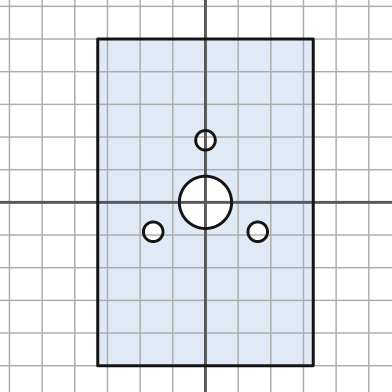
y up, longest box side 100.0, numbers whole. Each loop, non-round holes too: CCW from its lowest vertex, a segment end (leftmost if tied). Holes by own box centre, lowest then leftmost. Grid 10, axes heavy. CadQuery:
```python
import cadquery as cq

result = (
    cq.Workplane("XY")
    .moveTo(-33.0, -50.0)
    .lineTo(33.0, -50.0)
    .lineTo(33.0, 50.0)
    .lineTo(-33.0, 50.0)
    .close()
    .moveTo(-16.0, -9.0)
    .circle(3.0)
    .moveTo(16.0, -9.0)
    .circle(3.0)
    .moveTo(0.0, 0.0)
    .circle(8.0)
    .moveTo(0.0, 19.0)
    .circle(3.0)
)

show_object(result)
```